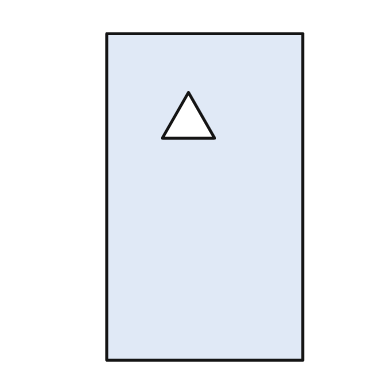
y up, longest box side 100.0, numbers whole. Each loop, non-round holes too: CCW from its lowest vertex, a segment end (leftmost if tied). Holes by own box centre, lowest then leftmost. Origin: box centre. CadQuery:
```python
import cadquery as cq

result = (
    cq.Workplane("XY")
    .moveTo(-30.0, -50.0)
    .lineTo(30.0, -50.0)
    .lineTo(30.0, 50.0)
    .lineTo(-30.0, 50.0)
    .close()
    .moveTo(-13.0, 18.0)
    .lineTo(3.0, 18.0)
    .lineTo(-5.0, 32.0)
    .close()
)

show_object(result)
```